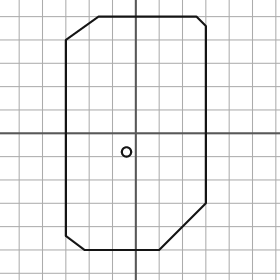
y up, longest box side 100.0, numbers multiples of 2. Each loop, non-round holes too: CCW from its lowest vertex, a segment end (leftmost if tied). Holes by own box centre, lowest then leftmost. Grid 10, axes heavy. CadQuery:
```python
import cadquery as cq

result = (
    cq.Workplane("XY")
    .moveTo(-22.0, -50.0)
    .lineTo(10.0, -50.0)
    .lineTo(30.0, -30.0)
    .lineTo(30.0, 46.0)
    .lineTo(26.0, 50.0)
    .lineTo(-16.0, 50.0)
    .lineTo(-30.0, 40.0)
    .lineTo(-30.0, -44.0)
    .close()
    .moveTo(-4.0, -8.0)
    .circle(2.0)
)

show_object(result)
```